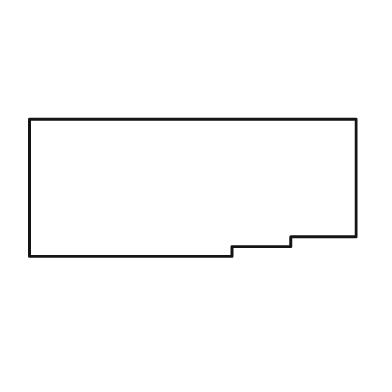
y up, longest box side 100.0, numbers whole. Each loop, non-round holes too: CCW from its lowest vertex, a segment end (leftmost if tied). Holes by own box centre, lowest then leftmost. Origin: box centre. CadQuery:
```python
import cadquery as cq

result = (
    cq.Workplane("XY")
    .moveTo(-50.0, -21.0)
    .lineTo(12.0, -21.0)
    .lineTo(12.0, -18.0)
    .lineTo(30.0, -18.0)
    .lineTo(30.0, -15.0)
    .lineTo(50.0, -15.0)
    .lineTo(50.0, 21.0)
    .lineTo(-50.0, 21.0)
    .close()
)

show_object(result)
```